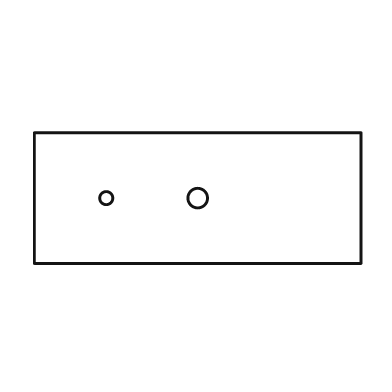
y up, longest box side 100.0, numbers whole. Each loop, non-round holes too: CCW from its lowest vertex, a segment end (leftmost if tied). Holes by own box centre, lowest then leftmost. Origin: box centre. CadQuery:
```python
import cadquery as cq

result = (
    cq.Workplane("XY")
    .moveTo(-50.0, -20.0)
    .lineTo(50.0, -20.0)
    .lineTo(50.0, 20.0)
    .lineTo(-50.0, 20.0)
    .close()
    .moveTo(-28.0, 0.0)
    .circle(2.0)
    .moveTo(0.0, 0.0)
    .circle(3.0)
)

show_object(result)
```